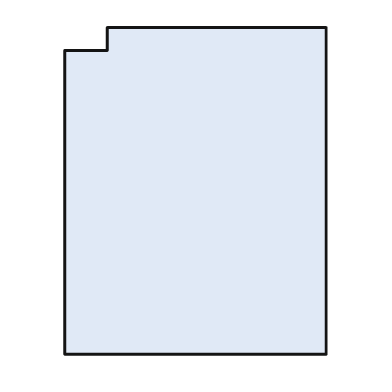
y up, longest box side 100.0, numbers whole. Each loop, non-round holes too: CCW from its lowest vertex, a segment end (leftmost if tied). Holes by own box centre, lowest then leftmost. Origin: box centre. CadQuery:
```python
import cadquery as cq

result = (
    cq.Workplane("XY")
    .moveTo(-40.0, -50.0)
    .lineTo(40.0, -50.0)
    .lineTo(40.0, 50.0)
    .lineTo(-27.0, 50.0)
    .lineTo(-27.0, 43.0)
    .lineTo(-40.0, 43.0)
    .close()
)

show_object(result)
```